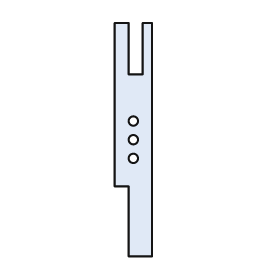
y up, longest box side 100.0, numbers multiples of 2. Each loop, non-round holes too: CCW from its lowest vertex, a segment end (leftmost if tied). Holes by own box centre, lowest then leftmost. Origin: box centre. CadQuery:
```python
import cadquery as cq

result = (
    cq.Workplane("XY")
    .moveTo(-2.0, -50.0)
    .lineTo(8.0, -50.0)
    .lineTo(8.0, 50.0)
    .lineTo(4.0, 50.0)
    .lineTo(4.0, 28.0)
    .lineTo(-2.0, 28.0)
    .lineTo(-2.0, 50.0)
    .lineTo(-8.0, 50.0)
    .lineTo(-8.0, -20.0)
    .lineTo(-2.0, -20.0)
    .close()
    .moveTo(0.0, -8.0)
    .circle(2.0)
    .moveTo(0.0, 0.0)
    .circle(2.0)
    .moveTo(0.0, 8.0)
    .circle(2.0)
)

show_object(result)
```